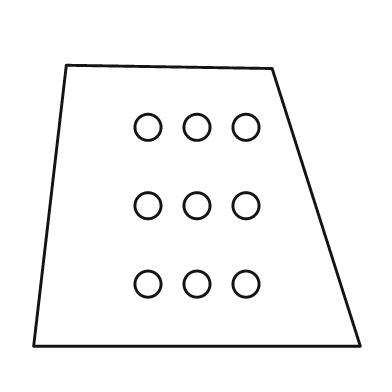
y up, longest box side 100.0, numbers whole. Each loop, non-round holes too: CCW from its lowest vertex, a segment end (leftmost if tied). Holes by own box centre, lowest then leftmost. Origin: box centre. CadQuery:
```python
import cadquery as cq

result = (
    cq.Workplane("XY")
    .moveTo(-50.0, -43.0)
    .lineTo(50.0, -43.0)
    .lineTo(23.0, 42.0)
    .lineTo(-40.0, 43.0)
    .close()
    .moveTo(-15.0, -24.0)
    .circle(4.0)
    .moveTo(0.0, -24.0)
    .circle(4.0)
    .moveTo(15.0, -24.0)
    .circle(4.0)
    .moveTo(-15.0, 0.0)
    .circle(4.0)
    .moveTo(0.0, 0.0)
    .circle(4.0)
    .moveTo(15.0, 0.0)
    .circle(4.0)
    .moveTo(-15.0, 24.0)
    .circle(4.0)
    .moveTo(0.0, 24.0)
    .circle(4.0)
    .moveTo(15.0, 24.0)
    .circle(4.0)
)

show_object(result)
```